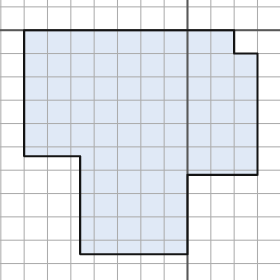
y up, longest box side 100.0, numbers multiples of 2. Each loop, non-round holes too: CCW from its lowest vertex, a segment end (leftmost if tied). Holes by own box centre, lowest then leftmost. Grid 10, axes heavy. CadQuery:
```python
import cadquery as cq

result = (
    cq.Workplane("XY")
    .moveTo(-46.0, -96.0)
    .lineTo(0.0, -96.0)
    .lineTo(0.0, -62.0)
    .lineTo(30.0, -62.0)
    .lineTo(30.0, -10.0)
    .lineTo(20.0, -10.0)
    .lineTo(20.0, 0.0)
    .lineTo(-70.0, 0.0)
    .lineTo(-70.0, -54.0)
    .lineTo(-46.0, -54.0)
    .close()
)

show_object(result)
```